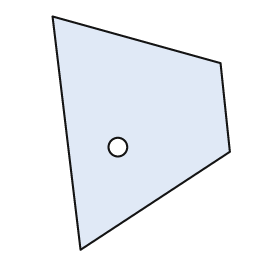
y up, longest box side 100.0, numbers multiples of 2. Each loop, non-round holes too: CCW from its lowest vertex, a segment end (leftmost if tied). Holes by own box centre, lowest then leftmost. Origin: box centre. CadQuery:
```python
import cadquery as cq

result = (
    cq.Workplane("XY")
    .moveTo(-26.0, -50.0)
    .lineTo(38.0, -8.0)
    .lineTo(34.0, 30.0)
    .lineTo(-38.0, 50.0)
    .close()
    .moveTo(-10.0, -6.0)
    .circle(4.0)
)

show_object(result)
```